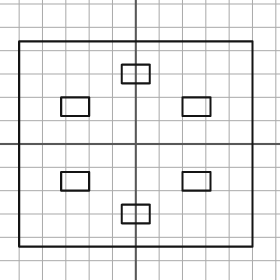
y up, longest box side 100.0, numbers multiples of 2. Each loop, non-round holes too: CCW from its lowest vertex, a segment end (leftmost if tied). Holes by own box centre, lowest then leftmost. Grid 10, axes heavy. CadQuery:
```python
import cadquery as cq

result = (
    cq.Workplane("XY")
    .moveTo(-50.0, -44.0)
    .lineTo(50.0, -44.0)
    .lineTo(50.0, 44.0)
    .lineTo(-50.0, 44.0)
    .close()
    .moveTo(-6.0, -34.0)
    .lineTo(6.0, -34.0)
    .lineTo(6.0, -26.0)
    .lineTo(-6.0, -26.0)
    .close()
    .moveTo(-32.0, -20.0)
    .lineTo(-20.0, -20.0)
    .lineTo(-20.0, -12.0)
    .lineTo(-32.0, -12.0)
    .close()
    .moveTo(20.0, -20.0)
    .lineTo(32.0, -20.0)
    .lineTo(32.0, -12.0)
    .lineTo(20.0, -12.0)
    .close()
    .moveTo(-32.0, 12.0)
    .lineTo(-20.0, 12.0)
    .lineTo(-20.0, 20.0)
    .lineTo(-32.0, 20.0)
    .close()
    .moveTo(20.0, 12.0)
    .lineTo(32.0, 12.0)
    .lineTo(32.0, 20.0)
    .lineTo(20.0, 20.0)
    .close()
    .moveTo(-6.0, 26.0)
    .lineTo(6.0, 26.0)
    .lineTo(6.0, 34.0)
    .lineTo(-6.0, 34.0)
    .close()
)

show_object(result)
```